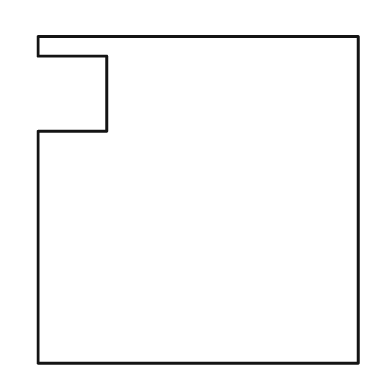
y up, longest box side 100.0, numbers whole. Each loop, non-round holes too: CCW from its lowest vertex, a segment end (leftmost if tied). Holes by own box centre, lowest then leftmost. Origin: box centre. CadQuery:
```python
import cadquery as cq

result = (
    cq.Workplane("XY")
    .moveTo(-49.0, -50.0)
    .lineTo(49.0, -50.0)
    .lineTo(49.0, 50.0)
    .lineTo(-49.0, 50.0)
    .lineTo(-49.0, 44.0)
    .lineTo(-28.0, 44.0)
    .lineTo(-28.0, 21.0)
    .lineTo(-49.0, 21.0)
    .close()
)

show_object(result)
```